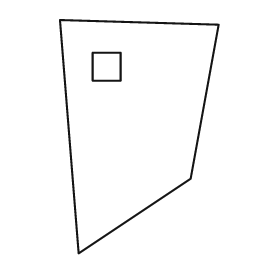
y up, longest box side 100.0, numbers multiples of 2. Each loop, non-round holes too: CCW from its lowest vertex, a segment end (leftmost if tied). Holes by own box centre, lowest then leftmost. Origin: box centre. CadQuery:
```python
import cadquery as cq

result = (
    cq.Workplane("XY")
    .moveTo(-26.0, -50.0)
    .lineTo(22.0, -18.0)
    .lineTo(34.0, 48.0)
    .lineTo(-34.0, 50.0)
    .close()
    .moveTo(-20.0, 24.0)
    .lineTo(-8.0, 24.0)
    .lineTo(-8.0, 36.0)
    .lineTo(-20.0, 36.0)
    .close()
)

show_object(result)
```